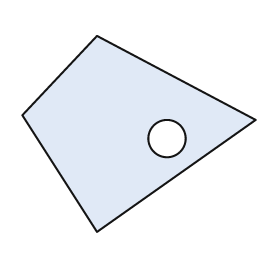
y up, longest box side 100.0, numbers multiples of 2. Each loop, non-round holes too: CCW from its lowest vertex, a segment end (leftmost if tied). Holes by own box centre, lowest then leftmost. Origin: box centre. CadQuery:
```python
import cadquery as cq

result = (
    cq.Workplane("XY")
    .moveTo(-18.0, -42.0)
    .lineTo(50.0, 6.0)
    .lineTo(-18.0, 42.0)
    .lineTo(-50.0, 8.0)
    .close()
    .moveTo(12.0, -2.0)
    .circle(8.0)
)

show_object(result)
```